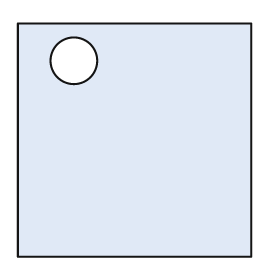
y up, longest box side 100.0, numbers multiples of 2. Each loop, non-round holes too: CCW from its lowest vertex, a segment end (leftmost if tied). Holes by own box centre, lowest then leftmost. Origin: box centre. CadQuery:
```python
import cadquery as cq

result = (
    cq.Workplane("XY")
    .moveTo(-50.0, -50.0)
    .lineTo(50.0, -50.0)
    .lineTo(50.0, 50.0)
    .lineTo(-50.0, 50.0)
    .close()
    .moveTo(-26.0, 34.0)
    .circle(10.0)
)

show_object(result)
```